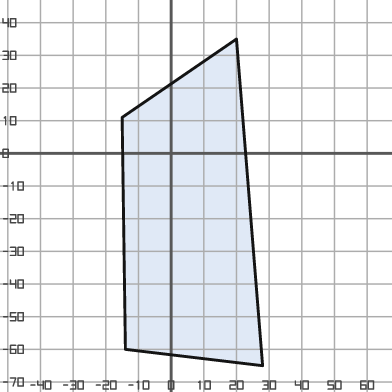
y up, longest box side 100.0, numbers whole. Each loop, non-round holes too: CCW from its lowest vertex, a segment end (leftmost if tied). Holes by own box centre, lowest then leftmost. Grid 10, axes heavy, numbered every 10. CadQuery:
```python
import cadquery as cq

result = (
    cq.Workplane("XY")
    .moveTo(28.0, -65.0)
    .lineTo(20.0, 35.0)
    .lineTo(-15.0, 11.0)
    .lineTo(-14.0, -60.0)
    .close()
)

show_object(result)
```